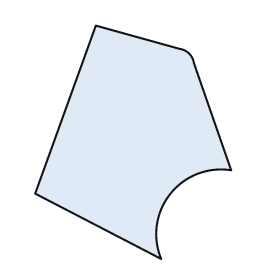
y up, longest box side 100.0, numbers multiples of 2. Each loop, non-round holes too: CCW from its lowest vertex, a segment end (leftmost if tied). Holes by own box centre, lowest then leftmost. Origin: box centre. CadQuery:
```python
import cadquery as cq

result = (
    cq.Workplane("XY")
    .moveTo(12.0, -50.0)
    .threePointArc((16.0, -22.0), (42.0, -12.0))
    .lineTo(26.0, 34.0)
    .threePointArc((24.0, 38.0), (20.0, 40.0))
    .lineTo(-16.0, 50.0)
    .lineTo(-42.0, -22.0)
    .close()
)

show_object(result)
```